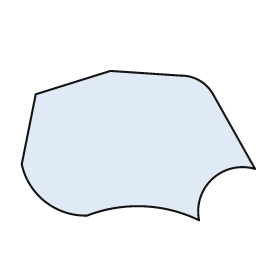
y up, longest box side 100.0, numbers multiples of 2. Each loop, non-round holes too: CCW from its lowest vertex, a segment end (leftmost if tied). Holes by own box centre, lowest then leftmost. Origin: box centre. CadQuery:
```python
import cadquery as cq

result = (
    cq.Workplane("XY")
    .moveTo(26.0, -32.0)
    .threePointArc((32.0, -14.0), (50.0, -10.0))
    .lineTo(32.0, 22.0)
    .threePointArc((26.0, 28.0), (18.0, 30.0))
    .lineTo(-12.0, 32.0)
    .lineTo(-44.0, 22.0)
    .lineTo(-50.0, -8.0)
    .threePointArc((-40.0, -24.0), (-22.0, -30.0))
    .threePointArc((2.0, -26.0), (26.0, -32.0))
    .close()
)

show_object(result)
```